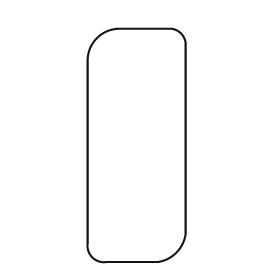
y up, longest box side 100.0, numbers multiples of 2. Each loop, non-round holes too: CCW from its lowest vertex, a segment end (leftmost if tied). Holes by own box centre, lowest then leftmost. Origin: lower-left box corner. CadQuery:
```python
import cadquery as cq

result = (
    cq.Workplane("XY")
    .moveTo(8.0, 0.0)
    .lineTo(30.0, 0.0)
    .threePointArc((38.0, 4.0), (42.0, 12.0))
    .lineTo(42.0, 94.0)
    .threePointArc((40.0, 98.0), (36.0, 100.0))
    .lineTo(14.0, 100.0)
    .threePointArc((4.0, 96.0), (0.0, 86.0))
    .lineTo(0.0, 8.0)
    .threePointArc((2.0, 2.0), (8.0, 0.0))
    .close()
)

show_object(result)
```